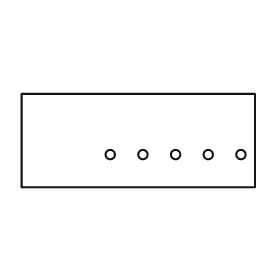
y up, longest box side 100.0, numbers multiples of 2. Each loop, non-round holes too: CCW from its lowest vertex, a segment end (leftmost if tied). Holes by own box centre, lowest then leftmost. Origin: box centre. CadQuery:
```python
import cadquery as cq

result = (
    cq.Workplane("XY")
    .moveTo(-50.0, -20.0)
    .lineTo(50.0, -20.0)
    .lineTo(50.0, 20.0)
    .lineTo(-50.0, 20.0)
    .close()
    .moveTo(-12.0, -6.0)
    .circle(2.0)
    .moveTo(2.0, -6.0)
    .circle(2.0)
    .moveTo(16.0, -6.0)
    .circle(2.0)
    .moveTo(30.0, -6.0)
    .circle(2.0)
    .moveTo(44.0, -6.0)
    .circle(2.0)
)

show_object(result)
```